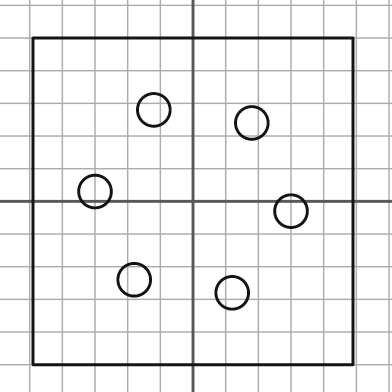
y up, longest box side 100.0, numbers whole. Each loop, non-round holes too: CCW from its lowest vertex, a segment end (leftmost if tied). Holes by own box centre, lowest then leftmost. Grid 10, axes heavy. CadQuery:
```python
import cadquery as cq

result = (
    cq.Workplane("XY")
    .moveTo(-49.0, -50.0)
    .lineTo(49.0, -50.0)
    .lineTo(49.0, 50.0)
    .lineTo(-49.0, 50.0)
    .close()
    .moveTo(12.0, -28.0)
    .circle(5.0)
    .moveTo(-18.0, -24.0)
    .circle(5.0)
    .moveTo(30.0, -3.0)
    .circle(5.0)
    .moveTo(-30.0, 3.0)
    .circle(5.0)
    .moveTo(18.0, 24.0)
    .circle(5.0)
    .moveTo(-12.0, 28.0)
    .circle(5.0)
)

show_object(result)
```